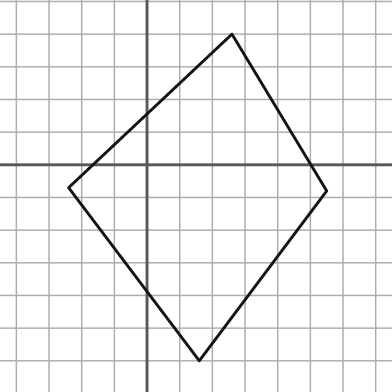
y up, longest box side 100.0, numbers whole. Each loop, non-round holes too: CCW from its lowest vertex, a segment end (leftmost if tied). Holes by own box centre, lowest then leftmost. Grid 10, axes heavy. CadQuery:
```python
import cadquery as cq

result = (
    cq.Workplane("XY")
    .moveTo(16.0, -60.0)
    .lineTo(55.0, -8.0)
    .lineTo(26.0, 40.0)
    .lineTo(-24.0, -7.0)
    .close()
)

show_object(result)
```